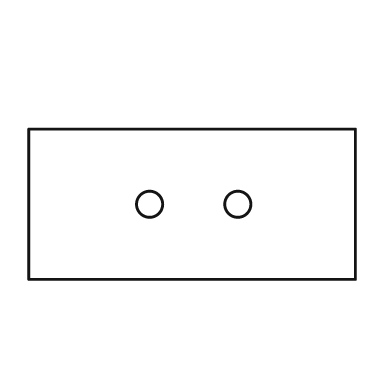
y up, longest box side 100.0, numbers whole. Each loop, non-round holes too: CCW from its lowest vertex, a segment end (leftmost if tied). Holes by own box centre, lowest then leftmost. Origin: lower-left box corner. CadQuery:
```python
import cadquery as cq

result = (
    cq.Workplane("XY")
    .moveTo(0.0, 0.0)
    .lineTo(100.0, 0.0)
    .lineTo(100.0, 46.0)
    .lineTo(0.0, 46.0)
    .close()
    .moveTo(37.0, 23.0)
    .circle(4.0)
    .moveTo(64.0, 23.0)
    .circle(4.0)
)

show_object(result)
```